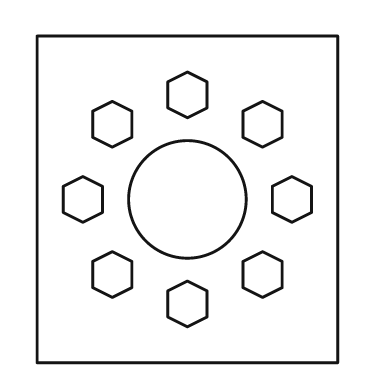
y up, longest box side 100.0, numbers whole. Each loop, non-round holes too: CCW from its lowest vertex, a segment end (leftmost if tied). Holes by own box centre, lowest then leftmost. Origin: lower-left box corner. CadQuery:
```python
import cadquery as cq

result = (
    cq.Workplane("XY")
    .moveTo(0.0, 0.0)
    .lineTo(92.0, 0.0)
    .lineTo(92.0, 100.0)
    .lineTo(0.0, 100.0)
    .close()
    .moveTo(46.0, 11.0)
    .lineTo(52.0, 14.0)
    .lineTo(52.0, 22.0)
    .lineTo(46.0, 25.0)
    .lineTo(40.0, 22.0)
    .lineTo(40.0, 14.0)
    .close()
    .moveTo(23.0, 20.0)
    .lineTo(29.0, 23.0)
    .lineTo(29.0, 31.0)
    .lineTo(23.0, 34.0)
    .lineTo(17.0, 31.0)
    .lineTo(17.0, 23.0)
    .close()
    .moveTo(69.0, 20.0)
    .lineTo(75.0, 23.0)
    .lineTo(75.0, 31.0)
    .lineTo(69.0, 34.0)
    .lineTo(63.0, 31.0)
    .lineTo(63.0, 23.0)
    .close()
    .moveTo(14.0, 43.0)
    .lineTo(20.0, 46.0)
    .lineTo(20.0, 54.0)
    .lineTo(14.0, 57.0)
    .lineTo(8.0, 54.0)
    .lineTo(8.0, 46.0)
    .close()
    .moveTo(46.0, 50.0)
    .circle(18.0)
    .moveTo(78.0, 43.0)
    .lineTo(84.0, 46.0)
    .lineTo(84.0, 54.0)
    .lineTo(78.0, 57.0)
    .lineTo(72.0, 54.0)
    .lineTo(72.0, 46.0)
    .close()
    .moveTo(23.0, 66.0)
    .lineTo(29.0, 69.0)
    .lineTo(29.0, 77.0)
    .lineTo(23.0, 80.0)
    .lineTo(17.0, 77.0)
    .lineTo(17.0, 69.0)
    .close()
    .moveTo(69.0, 66.0)
    .lineTo(75.0, 69.0)
    .lineTo(75.0, 77.0)
    .lineTo(69.0, 80.0)
    .lineTo(63.0, 77.0)
    .lineTo(63.0, 69.0)
    .close()
    .moveTo(46.0, 75.0)
    .lineTo(52.0, 78.0)
    .lineTo(52.0, 86.0)
    .lineTo(46.0, 89.0)
    .lineTo(40.0, 86.0)
    .lineTo(40.0, 78.0)
    .close()
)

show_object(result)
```